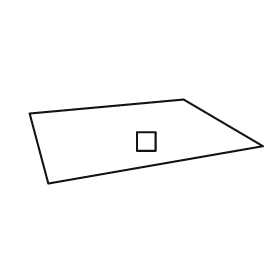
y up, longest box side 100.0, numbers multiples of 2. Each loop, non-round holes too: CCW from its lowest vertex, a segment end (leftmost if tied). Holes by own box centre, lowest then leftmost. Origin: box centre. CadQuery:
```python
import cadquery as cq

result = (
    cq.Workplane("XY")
    .moveTo(-42.0, -18.0)
    .lineTo(50.0, -2.0)
    .lineTo(16.0, 18.0)
    .lineTo(-50.0, 12.0)
    .close()
    .moveTo(-4.0, -4.0)
    .lineTo(4.0, -4.0)
    .lineTo(4.0, 4.0)
    .lineTo(-4.0, 4.0)
    .close()
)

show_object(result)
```